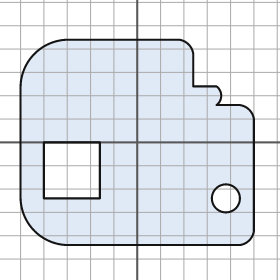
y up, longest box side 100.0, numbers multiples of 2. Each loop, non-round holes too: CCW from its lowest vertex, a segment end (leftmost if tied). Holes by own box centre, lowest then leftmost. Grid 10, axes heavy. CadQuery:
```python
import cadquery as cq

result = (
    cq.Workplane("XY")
    .moveTo(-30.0, -44.0)
    .lineTo(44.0, -44.0)
    .threePointArc((48.0, -42.0), (50.0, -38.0))
    .lineTo(50.0, 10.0)
    .threePointArc((48.0, 14.0), (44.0, 16.0))
    .lineTo(34.0, 16.0)
    .threePointArc((36.0, 20.0), (34.0, 24.0))
    .lineTo(24.0, 24.0)
    .lineTo(24.0, 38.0)
    .threePointArc((22.0, 42.0), (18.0, 44.0))
    .lineTo(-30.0, 44.0)
    .threePointArc((-44.0, 38.0), (-50.0, 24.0))
    .lineTo(-50.0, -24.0)
    .threePointArc((-44.0, -38.0), (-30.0, -44.0))
    .close()
    .moveTo(38.0, -24.0)
    .circle(6.0)
    .moveTo(-40.0, -24.0)
    .lineTo(-16.0, -24.0)
    .lineTo(-16.0, 0.0)
    .lineTo(-40.0, 0.0)
    .close()
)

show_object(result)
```